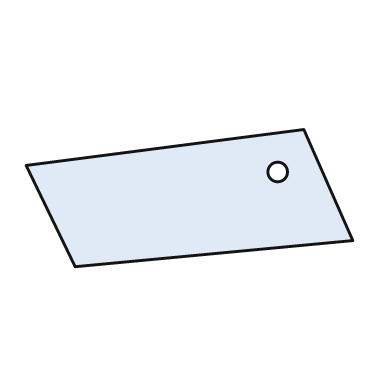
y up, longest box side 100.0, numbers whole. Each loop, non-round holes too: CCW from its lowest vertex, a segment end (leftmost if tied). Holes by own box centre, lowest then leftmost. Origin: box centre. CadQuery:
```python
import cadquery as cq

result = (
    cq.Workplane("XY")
    .moveTo(-35.0, -21.0)
    .lineTo(50.0, -13.0)
    .lineTo(35.0, 21.0)
    .lineTo(-50.0, 10.0)
    .close()
    .moveTo(27.0, 8.0)
    .circle(3.0)
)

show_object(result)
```